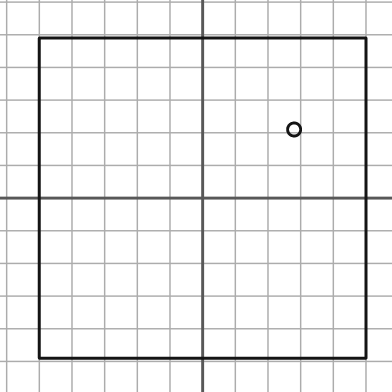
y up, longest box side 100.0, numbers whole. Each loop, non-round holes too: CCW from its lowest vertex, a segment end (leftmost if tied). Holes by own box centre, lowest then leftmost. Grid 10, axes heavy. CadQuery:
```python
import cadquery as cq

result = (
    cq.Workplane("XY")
    .moveTo(-50.0, -49.0)
    .lineTo(50.0, -49.0)
    .lineTo(50.0, 49.0)
    .lineTo(-50.0, 49.0)
    .close()
    .moveTo(28.0, 21.0)
    .circle(2.0)
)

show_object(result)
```